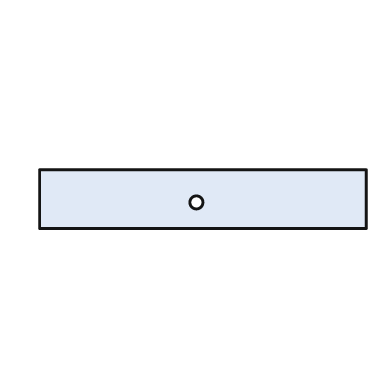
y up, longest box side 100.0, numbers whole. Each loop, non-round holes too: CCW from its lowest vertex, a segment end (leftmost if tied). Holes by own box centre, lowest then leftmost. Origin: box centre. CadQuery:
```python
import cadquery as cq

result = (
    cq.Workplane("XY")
    .moveTo(-50.0, -9.0)
    .lineTo(50.0, -9.0)
    .lineTo(50.0, 9.0)
    .lineTo(-50.0, 9.0)
    .close()
    .moveTo(-2.0, -1.0)
    .circle(2.0)
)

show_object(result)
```